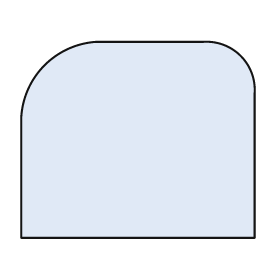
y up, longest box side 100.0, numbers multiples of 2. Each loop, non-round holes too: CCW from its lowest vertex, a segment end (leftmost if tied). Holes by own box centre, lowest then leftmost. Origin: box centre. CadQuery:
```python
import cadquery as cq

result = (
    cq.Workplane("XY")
    .moveTo(-50.0, -42.0)
    .lineTo(50.0, -42.0)
    .lineTo(50.0, 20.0)
    .threePointArc((44.0, 36.0), (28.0, 42.0))
    .lineTo(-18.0, 42.0)
    .threePointArc((-40.0, 32.0), (-50.0, 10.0))
    .close()
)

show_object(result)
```